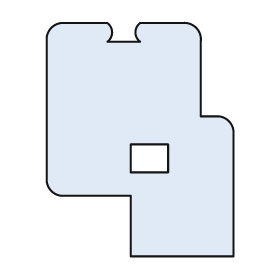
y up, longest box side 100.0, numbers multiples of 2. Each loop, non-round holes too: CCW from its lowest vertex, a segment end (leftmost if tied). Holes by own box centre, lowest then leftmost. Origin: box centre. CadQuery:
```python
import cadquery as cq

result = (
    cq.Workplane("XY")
    .moveTo(-4.0, -50.0)
    .lineTo(40.0, -50.0)
    .lineTo(40.0, 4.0)
    .threePointArc((38.0, 8.0), (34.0, 10.0))
    .lineTo(26.0, 10.0)
    .lineTo(26.0, 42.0)
    .threePointArc((24.0, 48.0), (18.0, 50.0))
    .lineTo(0.0, 50.0)
    .threePointArc((-2.0, 46.0), (0.0, 42.0))
    .lineTo(-14.0, 42.0)
    .threePointArc((-12.0, 46.0), (-14.0, 50.0))
    .lineTo(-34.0, 50.0)
    .threePointArc((-38.0, 48.0), (-40.0, 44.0))
    .lineTo(-40.0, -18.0)
    .threePointArc((-38.0, -22.0), (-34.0, -24.0))
    .lineTo(-4.0, -24.0)
    .close()
    .moveTo(-4.0, -14.0)
    .lineTo(12.0, -14.0)
    .lineTo(12.0, -2.0)
    .lineTo(-4.0, -2.0)
    .close()
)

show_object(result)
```